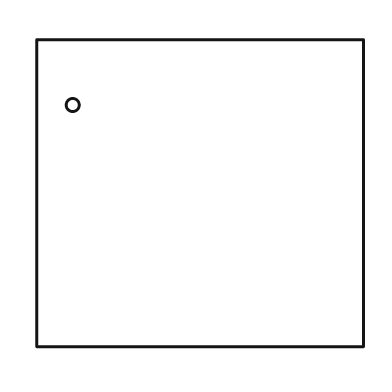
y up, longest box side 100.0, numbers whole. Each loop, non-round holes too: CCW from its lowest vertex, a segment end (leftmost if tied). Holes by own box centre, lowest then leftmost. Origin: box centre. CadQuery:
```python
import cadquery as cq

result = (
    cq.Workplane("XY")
    .moveTo(-50.0, -47.0)
    .lineTo(50.0, -47.0)
    .lineTo(50.0, 47.0)
    .lineTo(-50.0, 47.0)
    .close()
    .moveTo(-39.0, 27.0)
    .circle(2.0)
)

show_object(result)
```